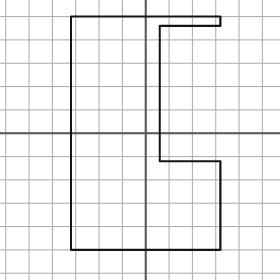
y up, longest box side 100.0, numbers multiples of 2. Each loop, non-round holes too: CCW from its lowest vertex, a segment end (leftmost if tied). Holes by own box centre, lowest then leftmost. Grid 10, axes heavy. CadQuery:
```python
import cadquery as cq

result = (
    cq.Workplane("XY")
    .moveTo(-32.0, -50.0)
    .lineTo(32.0, -50.0)
    .lineTo(32.0, -12.0)
    .lineTo(6.0, -12.0)
    .lineTo(6.0, 46.0)
    .lineTo(32.0, 46.0)
    .lineTo(32.0, 50.0)
    .lineTo(-32.0, 50.0)
    .close()
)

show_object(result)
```